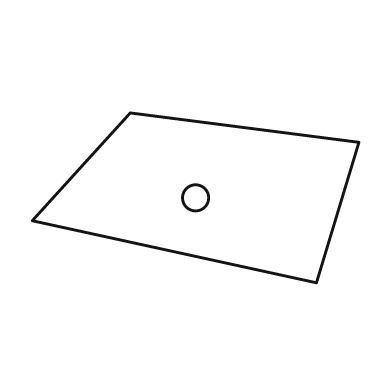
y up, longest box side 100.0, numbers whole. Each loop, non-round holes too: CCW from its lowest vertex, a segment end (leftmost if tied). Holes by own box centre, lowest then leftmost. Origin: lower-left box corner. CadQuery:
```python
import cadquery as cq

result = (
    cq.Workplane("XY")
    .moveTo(87.0, 0.0)
    .lineTo(100.0, 43.0)
    .lineTo(30.0, 52.0)
    .lineTo(0.0, 19.0)
    .close()
    .moveTo(50.0, 26.0)
    .circle(4.0)
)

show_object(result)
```